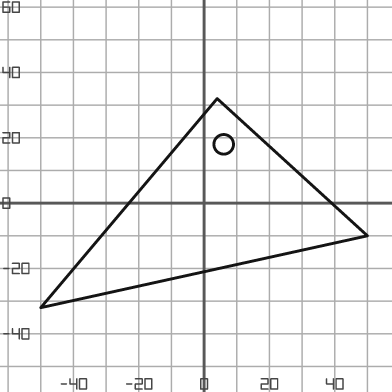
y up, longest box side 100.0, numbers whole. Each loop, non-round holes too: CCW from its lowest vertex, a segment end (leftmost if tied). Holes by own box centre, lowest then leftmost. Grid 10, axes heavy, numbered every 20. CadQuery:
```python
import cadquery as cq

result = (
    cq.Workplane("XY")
    .moveTo(-50.0, -32.0)
    .lineTo(50.0, -10.0)
    .lineTo(4.0, 32.0)
    .close()
    .moveTo(6.0, 18.0)
    .circle(3.0)
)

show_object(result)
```